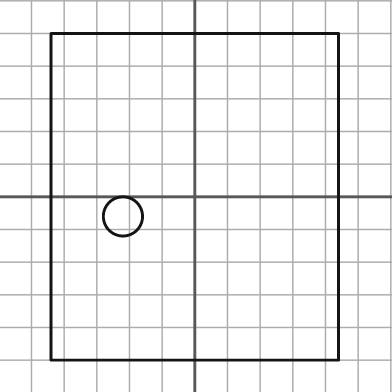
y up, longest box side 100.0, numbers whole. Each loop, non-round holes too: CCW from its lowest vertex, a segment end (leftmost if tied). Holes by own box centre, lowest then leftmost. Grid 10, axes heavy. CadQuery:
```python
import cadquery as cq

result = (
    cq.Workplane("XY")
    .moveTo(-44.0, -50.0)
    .lineTo(44.0, -50.0)
    .lineTo(44.0, 50.0)
    .lineTo(-44.0, 50.0)
    .close()
    .moveTo(-22.0, -6.0)
    .circle(6.0)
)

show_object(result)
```